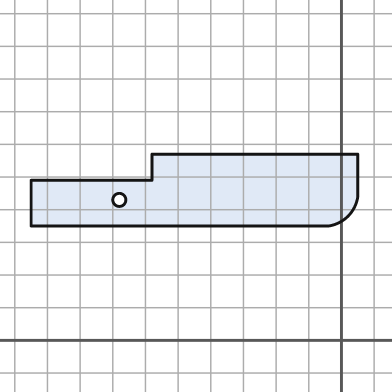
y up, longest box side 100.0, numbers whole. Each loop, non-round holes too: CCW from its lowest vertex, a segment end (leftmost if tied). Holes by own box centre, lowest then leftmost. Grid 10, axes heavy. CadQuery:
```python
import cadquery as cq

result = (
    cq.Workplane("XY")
    .moveTo(-95.0, 35.0)
    .lineTo(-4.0, 35.0)
    .threePointArc((2.0, 38.0), (5.0, 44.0))
    .lineTo(5.0, 57.0)
    .lineTo(-58.0, 57.0)
    .lineTo(-58.0, 49.0)
    .lineTo(-95.0, 49.0)
    .close()
    .moveTo(-68.0, 43.0)
    .circle(2.0)
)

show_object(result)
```